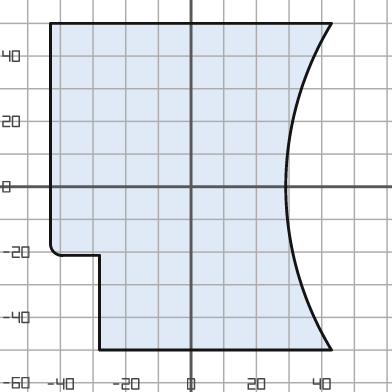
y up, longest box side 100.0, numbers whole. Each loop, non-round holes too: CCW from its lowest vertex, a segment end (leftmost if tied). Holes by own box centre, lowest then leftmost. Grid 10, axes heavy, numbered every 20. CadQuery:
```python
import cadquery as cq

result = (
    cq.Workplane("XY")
    .moveTo(-28.0, -50.0)
    .lineTo(43.0, -50.0)
    .threePointArc((29.0, 0.0), (43.0, 50.0))
    .lineTo(-43.0, 50.0)
    .lineTo(-43.0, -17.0)
    .threePointArc((-42.0, -20.0), (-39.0, -21.0))
    .lineTo(-28.0, -21.0)
    .close()
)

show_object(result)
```